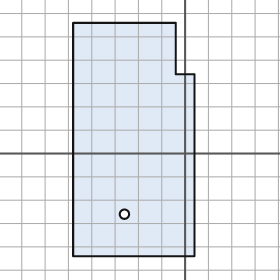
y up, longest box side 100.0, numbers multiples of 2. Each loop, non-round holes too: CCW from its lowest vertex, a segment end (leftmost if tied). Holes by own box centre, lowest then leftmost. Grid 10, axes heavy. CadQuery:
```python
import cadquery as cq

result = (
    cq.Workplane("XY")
    .moveTo(-48.0, -44.0)
    .lineTo(4.0, -44.0)
    .lineTo(4.0, 34.0)
    .lineTo(-4.0, 34.0)
    .lineTo(-4.0, 56.0)
    .lineTo(-48.0, 56.0)
    .close()
    .moveTo(-26.0, -26.0)
    .circle(2.0)
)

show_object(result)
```